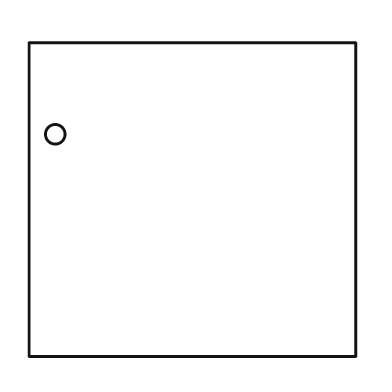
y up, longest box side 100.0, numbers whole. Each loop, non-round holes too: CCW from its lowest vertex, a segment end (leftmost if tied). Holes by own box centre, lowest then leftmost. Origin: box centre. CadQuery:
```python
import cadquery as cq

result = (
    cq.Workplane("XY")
    .moveTo(-50.0, -48.0)
    .lineTo(50.0, -48.0)
    .lineTo(50.0, 48.0)
    .lineTo(-50.0, 48.0)
    .close()
    .moveTo(-42.0, 20.0)
    .circle(3.0)
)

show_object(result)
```